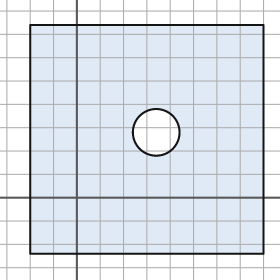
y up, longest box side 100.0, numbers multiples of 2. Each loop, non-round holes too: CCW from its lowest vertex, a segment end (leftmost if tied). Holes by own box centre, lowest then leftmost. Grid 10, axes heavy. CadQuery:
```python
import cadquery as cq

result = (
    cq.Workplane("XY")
    .moveTo(-20.0, -24.0)
    .lineTo(80.0, -24.0)
    .lineTo(80.0, 74.0)
    .lineTo(-20.0, 74.0)
    .close()
    .moveTo(34.0, 28.0)
    .circle(10.0)
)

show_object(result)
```